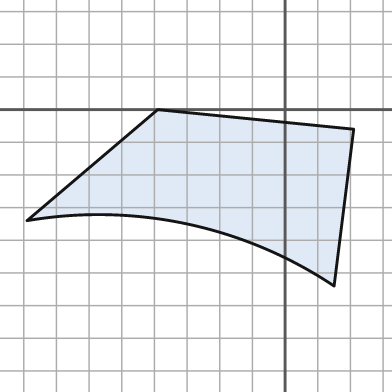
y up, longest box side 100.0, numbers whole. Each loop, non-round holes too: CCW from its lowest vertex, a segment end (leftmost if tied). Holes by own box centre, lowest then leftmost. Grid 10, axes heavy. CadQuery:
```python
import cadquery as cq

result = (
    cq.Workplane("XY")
    .moveTo(15.0, -54.0)
    .lineTo(21.0, -6.0)
    .lineTo(-39.0, 0.0)
    .lineTo(-79.0, -34.0)
    .threePointArc((-30.0, -35.0), (15.0, -54.0))
    .close()
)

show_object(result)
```